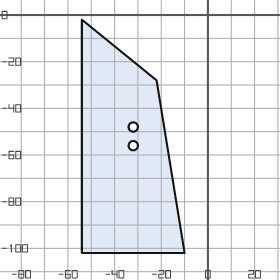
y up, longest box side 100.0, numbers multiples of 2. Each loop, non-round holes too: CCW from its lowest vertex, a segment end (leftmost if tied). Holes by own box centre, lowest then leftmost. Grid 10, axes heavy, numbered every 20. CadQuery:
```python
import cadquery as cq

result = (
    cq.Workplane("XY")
    .moveTo(-54.0, -102.0)
    .lineTo(-10.0, -102.0)
    .lineTo(-22.0, -28.0)
    .lineTo(-54.0, -2.0)
    .close()
    .moveTo(-32.0, -56.0)
    .circle(2.0)
    .moveTo(-32.0, -48.0)
    .circle(2.0)
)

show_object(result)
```